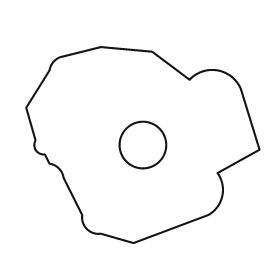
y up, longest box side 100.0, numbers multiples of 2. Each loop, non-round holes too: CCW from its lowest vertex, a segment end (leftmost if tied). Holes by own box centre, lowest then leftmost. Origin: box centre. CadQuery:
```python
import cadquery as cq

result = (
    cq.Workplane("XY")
    .moveTo(-4.0, -42.0)
    .lineTo(28.0, -30.0)
    .threePointArc((34.0, -22.0), (32.0, -12.0))
    .lineTo(50.0, -2.0)
    .lineTo(42.0, 24.0)
    .threePointArc((32.0, 32.0), (20.0, 28.0))
    .lineTo(4.0, 40.0)
    .lineTo(-18.0, 42.0)
    .lineTo(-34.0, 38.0)
    .threePointArc((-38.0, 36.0), (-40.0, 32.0))
    .lineTo(-50.0, 16.0)
    .lineTo(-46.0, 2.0)
    .threePointArc((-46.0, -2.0), (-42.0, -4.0))
    .lineTo(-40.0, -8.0)
    .threePointArc((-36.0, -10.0), (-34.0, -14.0))
    .lineTo(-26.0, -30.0)
    .threePointArc((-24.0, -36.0), (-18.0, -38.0))
    .close()
    .moveTo(0.0, 0.0)
    .circle(10.0)
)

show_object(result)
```